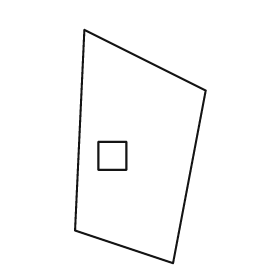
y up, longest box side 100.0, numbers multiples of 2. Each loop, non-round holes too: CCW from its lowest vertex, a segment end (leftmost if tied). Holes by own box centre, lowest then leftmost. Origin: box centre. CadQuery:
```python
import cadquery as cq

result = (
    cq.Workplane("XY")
    .moveTo(14.0, -50.0)
    .lineTo(28.0, 24.0)
    .lineTo(-24.0, 50.0)
    .lineTo(-28.0, -36.0)
    .close()
    .moveTo(-18.0, -10.0)
    .lineTo(-6.0, -10.0)
    .lineTo(-6.0, 2.0)
    .lineTo(-18.0, 2.0)
    .close()
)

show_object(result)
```